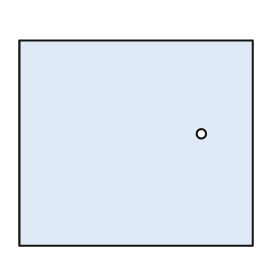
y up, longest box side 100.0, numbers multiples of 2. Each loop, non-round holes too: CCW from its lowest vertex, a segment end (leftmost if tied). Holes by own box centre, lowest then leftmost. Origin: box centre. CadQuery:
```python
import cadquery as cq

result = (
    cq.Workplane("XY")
    .moveTo(-50.0, -44.0)
    .lineTo(50.0, -44.0)
    .lineTo(50.0, 44.0)
    .lineTo(-50.0, 44.0)
    .close()
    .moveTo(28.0, 4.0)
    .circle(2.0)
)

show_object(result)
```